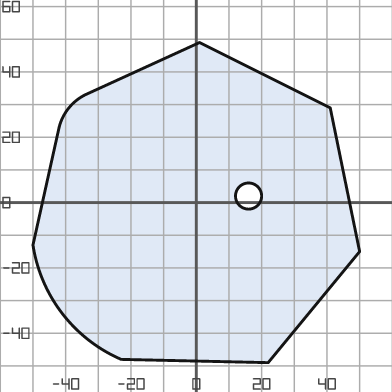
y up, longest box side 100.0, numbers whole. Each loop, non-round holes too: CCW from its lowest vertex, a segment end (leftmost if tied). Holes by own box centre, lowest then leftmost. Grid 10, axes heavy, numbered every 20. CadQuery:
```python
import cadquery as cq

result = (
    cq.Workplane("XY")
    .moveTo(22.0, -49.0)
    .lineTo(50.0, -15.0)
    .lineTo(41.0, 29.0)
    .lineTo(1.0, 49.0)
    .lineTo(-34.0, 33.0)
    .threePointArc((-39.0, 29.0), (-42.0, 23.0))
    .lineTo(-50.0, -13.0)
    .threePointArc((-41.0, -34.0), (-23.0, -48.0))
    .close()
    .moveTo(16.0, 2.0)
    .circle(4.0)
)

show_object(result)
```